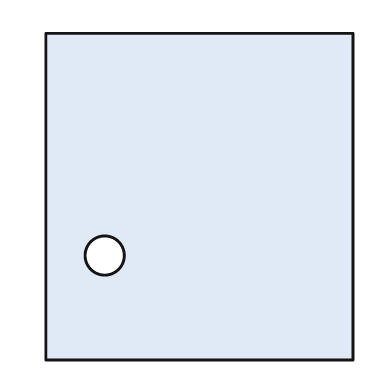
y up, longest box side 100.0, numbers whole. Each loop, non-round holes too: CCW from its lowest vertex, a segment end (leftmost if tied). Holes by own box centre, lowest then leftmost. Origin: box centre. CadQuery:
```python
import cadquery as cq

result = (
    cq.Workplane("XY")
    .moveTo(-47.0, -50.0)
    .lineTo(47.0, -50.0)
    .lineTo(47.0, 50.0)
    .lineTo(-47.0, 50.0)
    .close()
    .moveTo(-29.0, -18.0)
    .circle(6.0)
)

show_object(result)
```